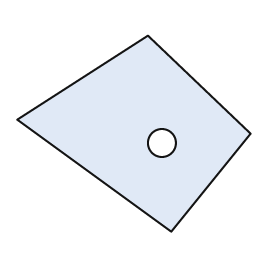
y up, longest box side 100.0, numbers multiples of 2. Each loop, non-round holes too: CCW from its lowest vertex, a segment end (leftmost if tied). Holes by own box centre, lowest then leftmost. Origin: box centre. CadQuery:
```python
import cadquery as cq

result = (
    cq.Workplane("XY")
    .moveTo(16.0, -42.0)
    .lineTo(50.0, 0.0)
    .lineTo(6.0, 42.0)
    .lineTo(-50.0, 6.0)
    .close()
    .moveTo(12.0, -4.0)
    .circle(6.0)
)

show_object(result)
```